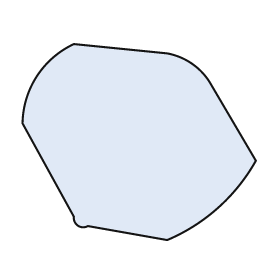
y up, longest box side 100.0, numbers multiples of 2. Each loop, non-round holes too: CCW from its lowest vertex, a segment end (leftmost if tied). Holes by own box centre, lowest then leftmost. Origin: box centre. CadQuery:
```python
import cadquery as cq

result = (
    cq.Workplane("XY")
    .moveTo(12.0, -42.0)
    .threePointArc((34.0, -28.0), (50.0, -8.0))
    .lineTo(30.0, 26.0)
    .threePointArc((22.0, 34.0), (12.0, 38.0))
    .lineTo(-28.0, 42.0)
    .threePointArc((-44.0, 28.0), (-50.0, 8.0))
    .lineTo(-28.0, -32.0)
    .threePointArc((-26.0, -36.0), (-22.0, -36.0))
    .close()
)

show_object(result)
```